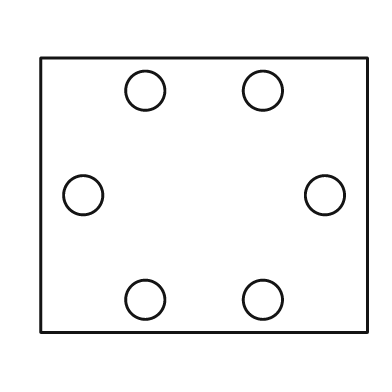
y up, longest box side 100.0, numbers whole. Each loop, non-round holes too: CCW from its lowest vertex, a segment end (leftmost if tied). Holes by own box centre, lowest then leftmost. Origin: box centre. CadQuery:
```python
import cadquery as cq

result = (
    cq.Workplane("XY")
    .moveTo(-50.0, -42.0)
    .lineTo(50.0, -42.0)
    .lineTo(50.0, 42.0)
    .lineTo(-50.0, 42.0)
    .close()
    .moveTo(-18.0, -32.0)
    .circle(6.0)
    .moveTo(18.0, -32.0)
    .circle(6.0)
    .moveTo(-37.0, 0.0)
    .circle(6.0)
    .moveTo(37.0, 0.0)
    .circle(6.0)
    .moveTo(-18.0, 32.0)
    .circle(6.0)
    .moveTo(18.0, 32.0)
    .circle(6.0)
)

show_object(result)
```